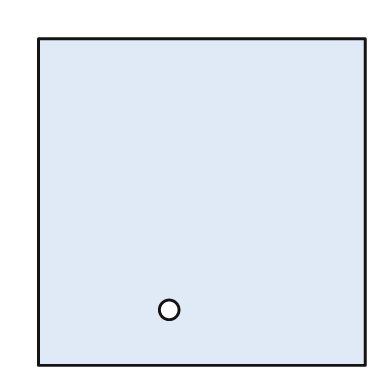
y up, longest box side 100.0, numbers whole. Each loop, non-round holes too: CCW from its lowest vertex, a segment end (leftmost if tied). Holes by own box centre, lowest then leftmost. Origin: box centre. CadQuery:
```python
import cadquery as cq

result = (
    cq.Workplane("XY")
    .moveTo(-50.0, -50.0)
    .lineTo(50.0, -50.0)
    .lineTo(50.0, 50.0)
    .lineTo(-50.0, 50.0)
    .close()
    .moveTo(-10.0, -33.0)
    .circle(3.0)
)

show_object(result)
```